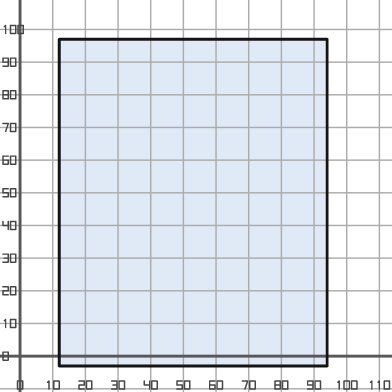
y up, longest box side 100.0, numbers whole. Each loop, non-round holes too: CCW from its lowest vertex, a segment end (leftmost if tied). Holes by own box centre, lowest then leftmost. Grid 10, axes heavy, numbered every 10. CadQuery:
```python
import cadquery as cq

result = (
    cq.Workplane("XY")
    .moveTo(12.0, -3.0)
    .lineTo(94.0, -3.0)
    .lineTo(94.0, 97.0)
    .lineTo(12.0, 97.0)
    .close()
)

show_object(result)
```